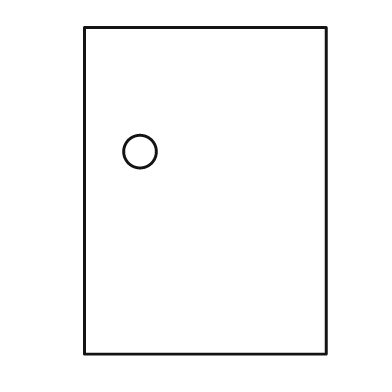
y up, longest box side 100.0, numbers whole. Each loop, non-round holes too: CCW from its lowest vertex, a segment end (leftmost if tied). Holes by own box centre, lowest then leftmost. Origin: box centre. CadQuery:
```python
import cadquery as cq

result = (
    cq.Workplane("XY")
    .moveTo(-37.0, -50.0)
    .lineTo(37.0, -50.0)
    .lineTo(37.0, 50.0)
    .lineTo(-37.0, 50.0)
    .close()
    .moveTo(-20.0, 12.0)
    .circle(5.0)
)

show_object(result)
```